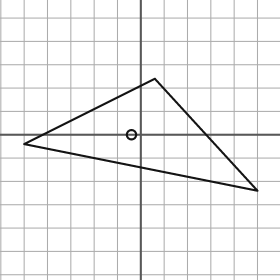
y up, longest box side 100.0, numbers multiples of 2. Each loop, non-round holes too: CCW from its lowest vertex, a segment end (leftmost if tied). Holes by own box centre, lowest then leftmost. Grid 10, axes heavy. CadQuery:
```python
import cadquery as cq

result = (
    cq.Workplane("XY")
    .moveTo(50.0, -24.0)
    .lineTo(6.0, 24.0)
    .lineTo(-50.0, -4.0)
    .close()
    .moveTo(-4.0, 0.0)
    .circle(2.0)
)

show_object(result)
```